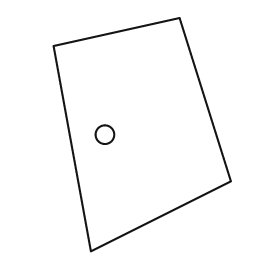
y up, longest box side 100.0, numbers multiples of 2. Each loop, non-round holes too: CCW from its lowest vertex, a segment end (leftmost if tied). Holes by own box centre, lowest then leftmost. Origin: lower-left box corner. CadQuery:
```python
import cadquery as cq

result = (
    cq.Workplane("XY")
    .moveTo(16.0, 0.0)
    .lineTo(76.0, 30.0)
    .lineTo(54.0, 100.0)
    .lineTo(0.0, 88.0)
    .close()
    .moveTo(22.0, 50.0)
    .circle(4.0)
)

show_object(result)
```